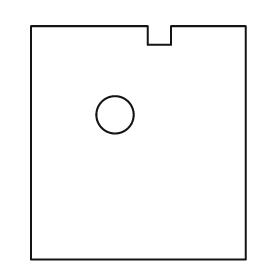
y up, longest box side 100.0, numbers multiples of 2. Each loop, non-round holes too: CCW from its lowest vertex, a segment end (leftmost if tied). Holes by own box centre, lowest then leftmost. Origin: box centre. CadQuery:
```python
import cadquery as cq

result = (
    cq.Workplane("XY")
    .moveTo(-46.0, -50.0)
    .lineTo(46.0, -50.0)
    .lineTo(46.0, 50.0)
    .lineTo(14.0, 50.0)
    .lineTo(14.0, 42.0)
    .lineTo(4.0, 42.0)
    .lineTo(4.0, 50.0)
    .lineTo(-46.0, 50.0)
    .close()
    .moveTo(-10.0, 12.0)
    .circle(8.0)
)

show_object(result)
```